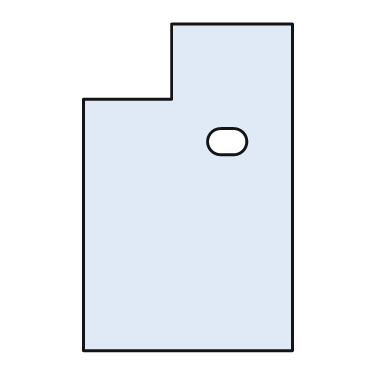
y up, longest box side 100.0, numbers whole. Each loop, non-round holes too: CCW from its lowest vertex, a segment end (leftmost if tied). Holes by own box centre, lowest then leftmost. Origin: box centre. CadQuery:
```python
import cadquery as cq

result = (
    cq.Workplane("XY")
    .moveTo(-32.0, -50.0)
    .lineTo(32.0, -50.0)
    .lineTo(32.0, 50.0)
    .lineTo(-5.0, 50.0)
    .lineTo(-5.0, 27.0)
    .lineTo(-32.0, 27.0)
    .close()
    .moveTo(10.0, 10.0)
    .lineTo(14.0, 10.0)
    .threePointArc((18.0, 14.0), (14.0, 18.0))
    .lineTo(10.0, 18.0)
    .threePointArc((6.0, 14.0), (10.0, 10.0))
    .close()
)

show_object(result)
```